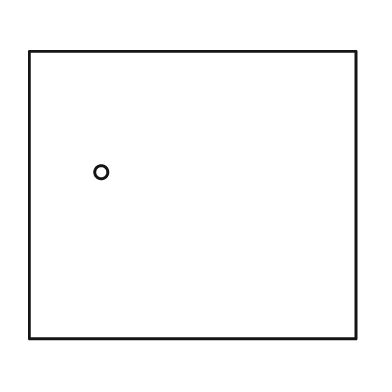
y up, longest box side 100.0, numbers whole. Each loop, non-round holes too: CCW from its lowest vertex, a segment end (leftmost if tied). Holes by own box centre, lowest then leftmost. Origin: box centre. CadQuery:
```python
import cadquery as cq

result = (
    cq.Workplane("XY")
    .moveTo(-50.0, -44.0)
    .lineTo(50.0, -44.0)
    .lineTo(50.0, 44.0)
    .lineTo(-50.0, 44.0)
    .close()
    .moveTo(-28.0, 7.0)
    .circle(2.0)
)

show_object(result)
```